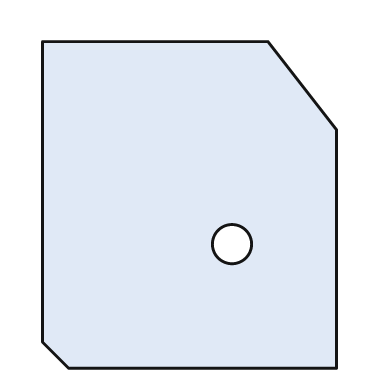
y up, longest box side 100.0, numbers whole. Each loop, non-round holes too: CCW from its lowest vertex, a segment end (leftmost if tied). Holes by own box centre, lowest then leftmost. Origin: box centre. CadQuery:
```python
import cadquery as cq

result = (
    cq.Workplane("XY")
    .moveTo(-37.0, -50.0)
    .lineTo(45.0, -50.0)
    .lineTo(45.0, 23.0)
    .lineTo(24.0, 50.0)
    .lineTo(-45.0, 50.0)
    .lineTo(-45.0, -42.0)
    .close()
    .moveTo(13.0, -12.0)
    .circle(6.0)
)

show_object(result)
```